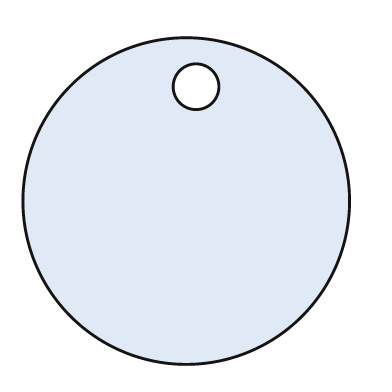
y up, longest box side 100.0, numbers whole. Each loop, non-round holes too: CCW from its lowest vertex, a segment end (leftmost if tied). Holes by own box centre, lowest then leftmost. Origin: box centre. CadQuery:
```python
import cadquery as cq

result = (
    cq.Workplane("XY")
    .moveTo(0.0, 0.0)
    .circle(50.0)
    .moveTo(3.0, 35.0)
    .circle(7.0)
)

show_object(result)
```